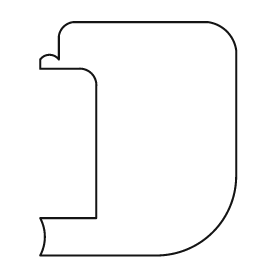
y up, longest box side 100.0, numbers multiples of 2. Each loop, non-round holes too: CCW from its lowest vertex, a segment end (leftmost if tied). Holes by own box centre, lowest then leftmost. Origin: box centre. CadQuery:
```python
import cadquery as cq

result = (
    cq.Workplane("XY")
    .moveTo(-42.0, -50.0)
    .lineTo(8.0, -50.0)
    .threePointArc((32.0, -40.0), (42.0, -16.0))
    .lineTo(42.0, 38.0)
    .threePointArc((38.0, 46.0), (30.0, 50.0))
    .lineTo(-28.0, 50.0)
    .threePointArc((-32.0, 48.0), (-34.0, 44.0))
    .lineTo(-34.0, 34.0)
    .threePointArc((-38.0, 36.0), (-42.0, 34.0))
    .lineTo(-42.0, 30.0)
    .lineTo(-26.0, 30.0)
    .threePointArc((-20.0, 28.0), (-18.0, 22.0))
    .lineTo(-18.0, -34.0)
    .lineTo(-42.0, -34.0)
    .threePointArc((-40.0, -42.0), (-42.0, -50.0))
    .close()
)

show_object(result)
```